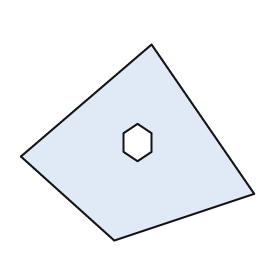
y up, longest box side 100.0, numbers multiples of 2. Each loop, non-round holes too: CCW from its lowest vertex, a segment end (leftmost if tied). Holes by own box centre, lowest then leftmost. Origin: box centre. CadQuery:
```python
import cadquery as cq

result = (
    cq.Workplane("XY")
    .moveTo(-10.0, -42.0)
    .lineTo(50.0, -22.0)
    .lineTo(6.0, 42.0)
    .lineTo(-50.0, -6.0)
    .close()
    .moveTo(0.0, -8.0)
    .lineTo(6.0, -4.0)
    .lineTo(6.0, 4.0)
    .lineTo(0.0, 8.0)
    .lineTo(-6.0, 4.0)
    .lineTo(-6.0, -4.0)
    .close()
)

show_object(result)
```